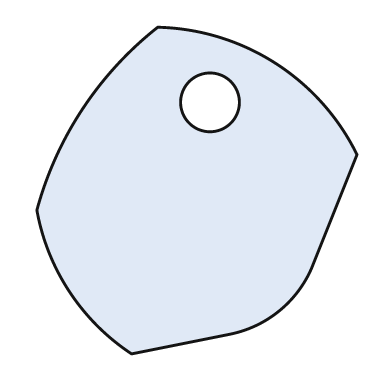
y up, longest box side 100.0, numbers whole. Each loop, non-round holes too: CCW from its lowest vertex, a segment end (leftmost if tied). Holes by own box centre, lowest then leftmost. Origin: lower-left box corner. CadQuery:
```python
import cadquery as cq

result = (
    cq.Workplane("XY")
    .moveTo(29.0, 0.0)
    .lineTo(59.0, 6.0)
    .threePointArc((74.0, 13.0), (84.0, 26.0))
    .lineTo(98.0, 61.0)
    .threePointArc((73.0, 89.0), (37.0, 100.0))
    .threePointArc((14.0, 75.0), (0.0, 44.0))
    .threePointArc((10.0, 19.0), (29.0, 0.0))
    .close()
    .moveTo(53.0, 77.0)
    .circle(9.0)
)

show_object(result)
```